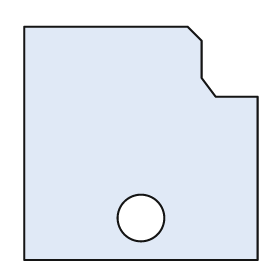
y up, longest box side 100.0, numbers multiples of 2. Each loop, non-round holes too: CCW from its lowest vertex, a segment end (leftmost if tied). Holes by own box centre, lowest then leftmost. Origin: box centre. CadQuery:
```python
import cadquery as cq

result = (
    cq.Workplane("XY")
    .moveTo(-50.0, -50.0)
    .lineTo(50.0, -50.0)
    .lineTo(50.0, 20.0)
    .lineTo(32.0, 20.0)
    .lineTo(26.0, 28.0)
    .lineTo(26.0, 44.0)
    .lineTo(20.0, 50.0)
    .lineTo(-50.0, 50.0)
    .close()
    .moveTo(0.0, -32.0)
    .circle(10.0)
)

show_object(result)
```